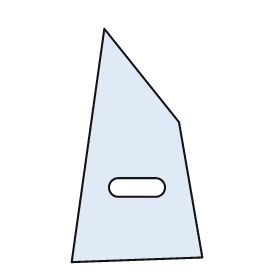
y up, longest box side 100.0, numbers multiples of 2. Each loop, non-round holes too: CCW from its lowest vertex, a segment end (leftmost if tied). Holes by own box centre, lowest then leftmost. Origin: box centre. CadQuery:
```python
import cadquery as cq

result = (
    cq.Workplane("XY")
    .moveTo(-28.0, -50.0)
    .lineTo(28.0, -48.0)
    .lineTo(18.0, 10.0)
    .lineTo(-14.0, 50.0)
    .close()
    .moveTo(-8.0, -22.0)
    .lineTo(8.0, -22.0)
    .threePointArc((12.0, -18.0), (8.0, -14.0))
    .lineTo(-8.0, -14.0)
    .threePointArc((-12.0, -18.0), (-8.0, -22.0))
    .close()
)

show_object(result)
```